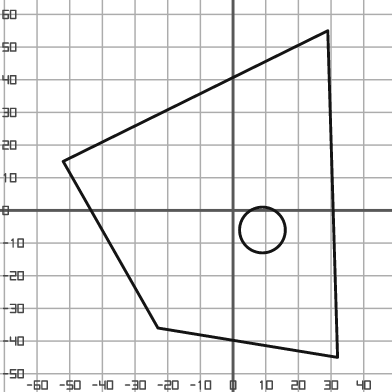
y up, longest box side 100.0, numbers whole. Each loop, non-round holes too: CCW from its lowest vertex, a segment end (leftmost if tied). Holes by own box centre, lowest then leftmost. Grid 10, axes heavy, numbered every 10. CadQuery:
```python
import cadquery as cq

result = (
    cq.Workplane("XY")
    .moveTo(32.0, -45.0)
    .lineTo(29.0, 55.0)
    .lineTo(-52.0, 15.0)
    .lineTo(-23.0, -36.0)
    .close()
    .moveTo(9.0, -6.0)
    .circle(7.0)
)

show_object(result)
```